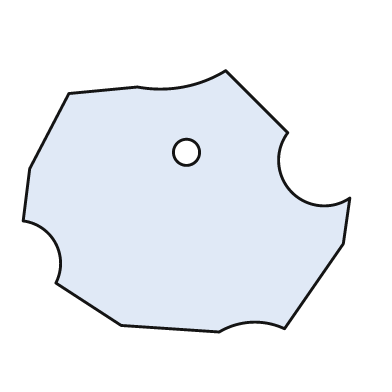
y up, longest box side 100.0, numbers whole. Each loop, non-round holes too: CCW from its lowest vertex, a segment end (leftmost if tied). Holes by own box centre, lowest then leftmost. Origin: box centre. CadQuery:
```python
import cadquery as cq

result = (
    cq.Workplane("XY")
    .moveTo(10.0, -40.0)
    .threePointArc((20.0, -37.0), (30.0, -39.0))
    .lineTo(48.0, -13.0)
    .lineTo(50.0, 1.0)
    .threePointArc((32.0, 3.0), (31.0, 21.0))
    .lineTo(12.0, 40.0)
    .threePointArc((-1.0, 35.0), (-15.0, 35.0))
    .lineTo(-36.0, 33.0)
    .lineTo(-48.0, 10.0)
    .lineTo(-50.0, -6.0)
    .threePointArc((-40.0, -13.0), (-40.0, -25.0))
    .lineTo(-20.0, -38.0)
    .close()
    .moveTo(0.0, 15.0)
    .circle(4.0)
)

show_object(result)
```